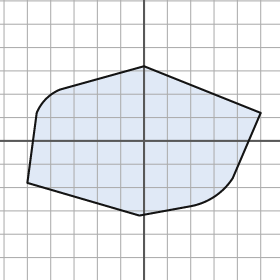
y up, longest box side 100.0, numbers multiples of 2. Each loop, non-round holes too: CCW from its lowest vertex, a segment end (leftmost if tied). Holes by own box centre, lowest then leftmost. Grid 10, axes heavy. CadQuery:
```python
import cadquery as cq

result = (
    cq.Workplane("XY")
    .moveTo(-2.0, -32.0)
    .lineTo(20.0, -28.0)
    .threePointArc((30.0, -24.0), (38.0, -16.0))
    .lineTo(50.0, 12.0)
    .lineTo(0.0, 32.0)
    .lineTo(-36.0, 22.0)
    .threePointArc((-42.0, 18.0), (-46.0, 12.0))
    .lineTo(-50.0, -18.0)
    .close()
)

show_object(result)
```